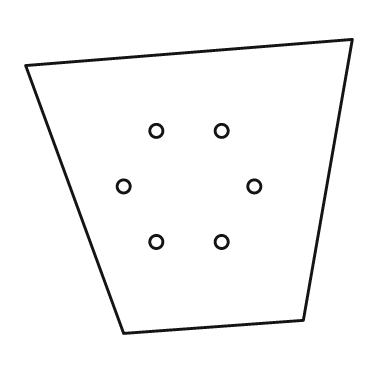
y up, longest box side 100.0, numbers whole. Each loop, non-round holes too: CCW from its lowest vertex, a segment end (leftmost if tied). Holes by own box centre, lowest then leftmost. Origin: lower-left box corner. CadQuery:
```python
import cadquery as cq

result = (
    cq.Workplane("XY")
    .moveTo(30.0, 0.0)
    .lineTo(85.0, 4.0)
    .lineTo(100.0, 90.0)
    .lineTo(0.0, 82.0)
    .close()
    .moveTo(40.0, 28.0)
    .circle(2.0)
    .moveTo(60.0, 28.0)
    .circle(2.0)
    .moveTo(30.0, 45.0)
    .circle(2.0)
    .moveTo(70.0, 45.0)
    .circle(2.0)
    .moveTo(40.0, 62.0)
    .circle(2.0)
    .moveTo(60.0, 62.0)
    .circle(2.0)
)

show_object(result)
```